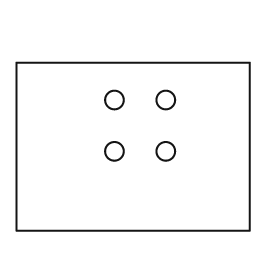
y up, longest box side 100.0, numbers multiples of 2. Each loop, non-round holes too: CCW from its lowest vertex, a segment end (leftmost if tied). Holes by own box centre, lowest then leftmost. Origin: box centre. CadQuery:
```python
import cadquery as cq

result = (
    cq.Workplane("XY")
    .moveTo(-50.0, -36.0)
    .lineTo(50.0, -36.0)
    .lineTo(50.0, 36.0)
    .lineTo(-50.0, 36.0)
    .close()
    .moveTo(-8.0, -2.0)
    .circle(4.0)
    .moveTo(14.0, -2.0)
    .circle(4.0)
    .moveTo(-8.0, 20.0)
    .circle(4.0)
    .moveTo(14.0, 20.0)
    .circle(4.0)
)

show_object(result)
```